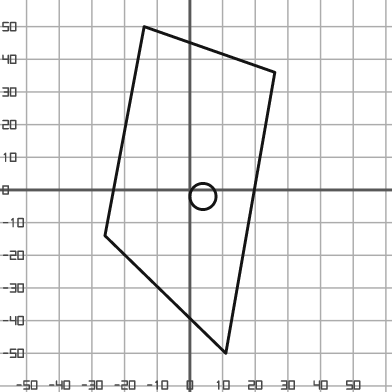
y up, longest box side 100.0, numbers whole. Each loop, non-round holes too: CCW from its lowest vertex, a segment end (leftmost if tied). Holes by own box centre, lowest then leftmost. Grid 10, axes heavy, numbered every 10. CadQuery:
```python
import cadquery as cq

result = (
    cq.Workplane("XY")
    .moveTo(11.0, -50.0)
    .lineTo(26.0, 36.0)
    .lineTo(-14.0, 50.0)
    .lineTo(-26.0, -14.0)
    .close()
    .moveTo(4.0, -2.0)
    .circle(4.0)
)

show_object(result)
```